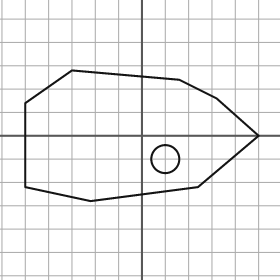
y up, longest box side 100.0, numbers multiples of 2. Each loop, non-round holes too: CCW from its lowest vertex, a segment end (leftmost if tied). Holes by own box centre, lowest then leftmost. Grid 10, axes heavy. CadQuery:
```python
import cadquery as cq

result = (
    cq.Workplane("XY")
    .moveTo(-22.0, -28.0)
    .lineTo(24.0, -22.0)
    .lineTo(50.0, 0.0)
    .lineTo(32.0, 16.0)
    .lineTo(16.0, 24.0)
    .lineTo(-30.0, 28.0)
    .lineTo(-50.0, 14.0)
    .lineTo(-50.0, -22.0)
    .close()
    .moveTo(10.0, -10.0)
    .circle(6.0)
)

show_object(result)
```